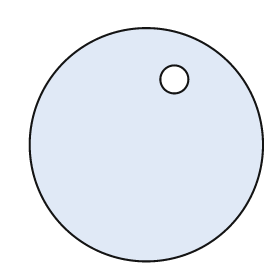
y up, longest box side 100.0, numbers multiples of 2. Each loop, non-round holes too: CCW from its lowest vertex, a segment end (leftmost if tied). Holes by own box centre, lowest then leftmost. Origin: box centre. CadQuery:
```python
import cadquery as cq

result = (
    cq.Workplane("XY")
    .moveTo(0.0, 0.0)
    .circle(50.0)
    .moveTo(12.0, 28.0)
    .circle(6.0)
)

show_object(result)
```